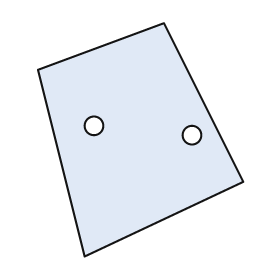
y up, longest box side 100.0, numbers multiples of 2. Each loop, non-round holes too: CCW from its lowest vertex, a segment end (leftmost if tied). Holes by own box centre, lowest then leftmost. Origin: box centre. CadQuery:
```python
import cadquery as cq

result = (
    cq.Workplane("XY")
    .moveTo(-24.0, -50.0)
    .lineTo(44.0, -18.0)
    .lineTo(10.0, 50.0)
    .lineTo(-44.0, 30.0)
    .close()
    .moveTo(22.0, 2.0)
    .circle(4.0)
    .moveTo(-20.0, 6.0)
    .circle(4.0)
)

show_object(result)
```